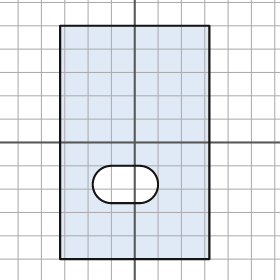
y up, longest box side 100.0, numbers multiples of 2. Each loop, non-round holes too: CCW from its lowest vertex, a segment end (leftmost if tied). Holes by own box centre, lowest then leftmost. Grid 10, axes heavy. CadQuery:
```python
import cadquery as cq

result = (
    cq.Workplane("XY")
    .moveTo(-32.0, -50.0)
    .lineTo(32.0, -50.0)
    .lineTo(32.0, 50.0)
    .lineTo(-32.0, 50.0)
    .close()
    .moveTo(-10.0, -26.0)
    .lineTo(2.0, -26.0)
    .threePointArc((10.0, -18.0), (2.0, -10.0))
    .lineTo(-10.0, -10.0)
    .threePointArc((-18.0, -18.0), (-10.0, -26.0))
    .close()
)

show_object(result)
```